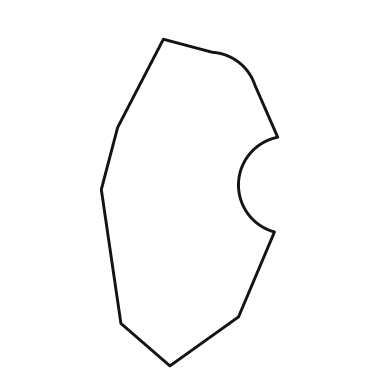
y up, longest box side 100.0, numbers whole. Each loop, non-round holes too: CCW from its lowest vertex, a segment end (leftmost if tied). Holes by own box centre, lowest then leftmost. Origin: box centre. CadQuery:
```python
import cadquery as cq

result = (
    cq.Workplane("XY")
    .moveTo(-6.0, -50.0)
    .lineTo(15.0, -35.0)
    .lineTo(26.0, -9.0)
    .threePointArc((15.0, 6.0), (27.0, 20.0))
    .lineTo(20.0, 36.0)
    .threePointArc((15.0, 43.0), (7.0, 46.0))
    .lineTo(-8.0, 50.0)
    .lineTo(-22.0, 23.0)
    .lineTo(-27.0, 4.0)
    .lineTo(-21.0, -37.0)
    .close()
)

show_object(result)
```